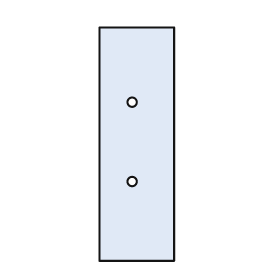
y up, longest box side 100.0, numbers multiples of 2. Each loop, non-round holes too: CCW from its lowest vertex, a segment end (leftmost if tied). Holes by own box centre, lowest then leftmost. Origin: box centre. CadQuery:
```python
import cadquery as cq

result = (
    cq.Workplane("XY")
    .moveTo(-16.0, -50.0)
    .lineTo(16.0, -50.0)
    .lineTo(16.0, 50.0)
    .lineTo(-16.0, 50.0)
    .close()
    .moveTo(-2.0, -16.0)
    .circle(2.0)
    .moveTo(-2.0, 18.0)
    .circle(2.0)
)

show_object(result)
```